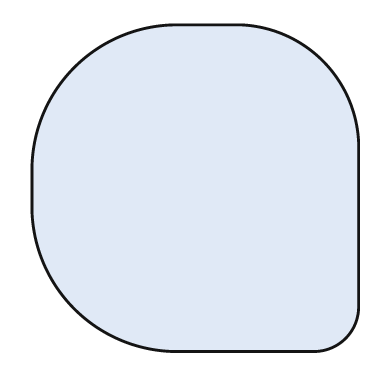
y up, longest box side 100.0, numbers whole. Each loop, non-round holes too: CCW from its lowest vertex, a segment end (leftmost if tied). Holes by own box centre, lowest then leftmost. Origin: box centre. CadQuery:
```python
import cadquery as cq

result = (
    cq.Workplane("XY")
    .moveTo(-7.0, -50.0)
    .lineTo(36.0, -50.0)
    .threePointArc((46.0, -46.0), (50.0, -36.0))
    .lineTo(50.0, 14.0)
    .threePointArc((39.0, 39.0), (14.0, 50.0))
    .lineTo(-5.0, 50.0)
    .threePointArc((-37.0, 37.0), (-50.0, 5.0))
    .lineTo(-50.0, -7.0)
    .threePointArc((-37.0, -37.0), (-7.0, -50.0))
    .close()
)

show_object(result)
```